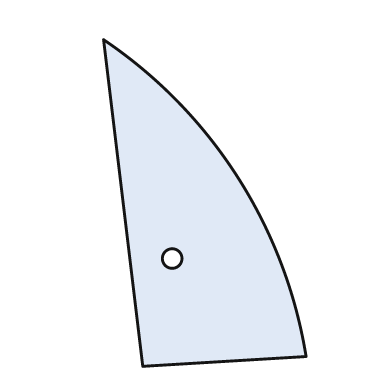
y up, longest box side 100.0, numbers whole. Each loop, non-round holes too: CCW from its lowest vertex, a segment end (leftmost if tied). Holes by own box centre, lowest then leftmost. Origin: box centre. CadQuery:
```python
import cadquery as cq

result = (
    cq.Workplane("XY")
    .moveTo(-19.0, -50.0)
    .lineTo(31.0, -47.0)
    .threePointArc((10.0, 8.0), (-31.0, 50.0))
    .close()
    .moveTo(-10.0, -17.0)
    .circle(3.0)
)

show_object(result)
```